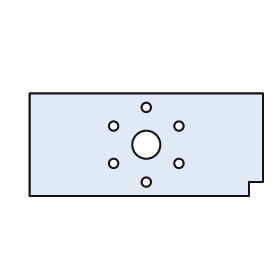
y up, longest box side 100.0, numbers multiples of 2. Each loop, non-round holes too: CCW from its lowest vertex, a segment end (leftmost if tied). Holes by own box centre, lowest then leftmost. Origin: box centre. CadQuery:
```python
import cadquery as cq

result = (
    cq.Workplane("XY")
    .moveTo(-50.0, -22.0)
    .lineTo(44.0, -22.0)
    .lineTo(44.0, -16.0)
    .lineTo(50.0, -16.0)
    .lineTo(50.0, 22.0)
    .lineTo(-50.0, 22.0)
    .close()
    .moveTo(0.0, -16.0)
    .circle(2.0)
    .moveTo(-14.0, -8.0)
    .circle(2.0)
    .moveTo(14.0, -8.0)
    .circle(2.0)
    .moveTo(0.0, 0.0)
    .circle(6.0)
    .moveTo(-14.0, 8.0)
    .circle(2.0)
    .moveTo(14.0, 8.0)
    .circle(2.0)
    .moveTo(0.0, 16.0)
    .circle(2.0)
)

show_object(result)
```